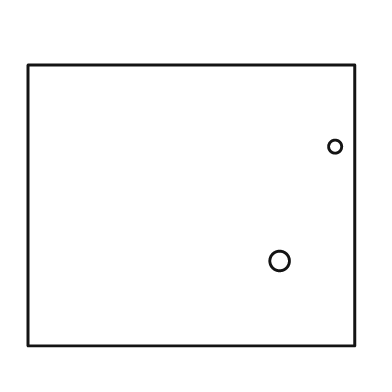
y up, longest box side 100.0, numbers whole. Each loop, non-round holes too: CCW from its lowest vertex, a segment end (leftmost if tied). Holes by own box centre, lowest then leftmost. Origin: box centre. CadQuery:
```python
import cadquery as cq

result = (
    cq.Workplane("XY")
    .moveTo(-50.0, -43.0)
    .lineTo(50.0, -43.0)
    .lineTo(50.0, 43.0)
    .lineTo(-50.0, 43.0)
    .close()
    .moveTo(27.0, -17.0)
    .circle(3.0)
    .moveTo(44.0, 18.0)
    .circle(2.0)
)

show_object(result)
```